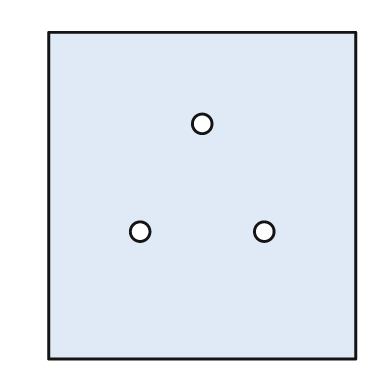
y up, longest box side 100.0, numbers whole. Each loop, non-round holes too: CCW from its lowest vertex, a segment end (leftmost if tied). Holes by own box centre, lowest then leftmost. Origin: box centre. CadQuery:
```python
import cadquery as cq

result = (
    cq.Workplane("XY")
    .moveTo(-47.0, -50.0)
    .lineTo(47.0, -50.0)
    .lineTo(47.0, 50.0)
    .lineTo(-47.0, 50.0)
    .close()
    .moveTo(-19.0, -11.0)
    .circle(3.0)
    .moveTo(19.0, -11.0)
    .circle(3.0)
    .moveTo(0.0, 22.0)
    .circle(3.0)
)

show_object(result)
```